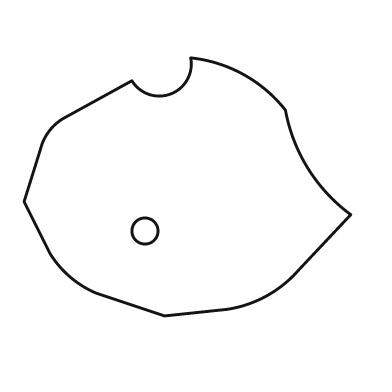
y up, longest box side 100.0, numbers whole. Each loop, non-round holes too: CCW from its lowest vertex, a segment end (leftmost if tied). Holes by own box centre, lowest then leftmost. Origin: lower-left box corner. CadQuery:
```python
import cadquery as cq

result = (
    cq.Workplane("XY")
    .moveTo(43.0, 0.0)
    .lineTo(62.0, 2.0)
    .threePointArc((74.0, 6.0), (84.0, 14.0))
    .lineTo(100.0, 31.0)
    .threePointArc((87.0, 45.0), (80.0, 63.0))
    .threePointArc((67.0, 74.0), (51.0, 79.0))
    .threePointArc((45.0, 68.0), (33.0, 72.0))
    .lineTo(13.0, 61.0)
    .threePointArc((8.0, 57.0), (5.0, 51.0))
    .lineTo(0.0, 35.0)
    .lineTo(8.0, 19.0)
    .threePointArc((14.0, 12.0), (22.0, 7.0))
    .close()
    .moveTo(37.0, 26.0)
    .circle(4.0)
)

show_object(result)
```